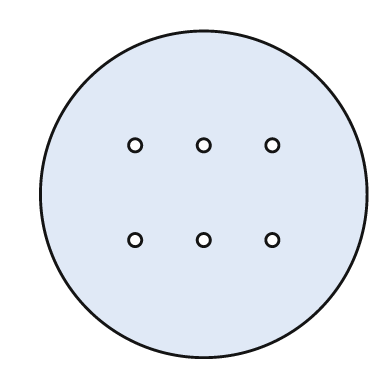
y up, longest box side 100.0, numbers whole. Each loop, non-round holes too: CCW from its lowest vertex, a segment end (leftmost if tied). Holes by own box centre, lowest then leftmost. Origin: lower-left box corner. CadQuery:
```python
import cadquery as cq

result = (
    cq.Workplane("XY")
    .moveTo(50.0, 50.0)
    .circle(50.0)
    .moveTo(29.0, 36.0)
    .circle(2.0)
    .moveTo(50.0, 36.0)
    .circle(2.0)
    .moveTo(71.0, 36.0)
    .circle(2.0)
    .moveTo(29.0, 65.0)
    .circle(2.0)
    .moveTo(50.0, 65.0)
    .circle(2.0)
    .moveTo(71.0, 65.0)
    .circle(2.0)
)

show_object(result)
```